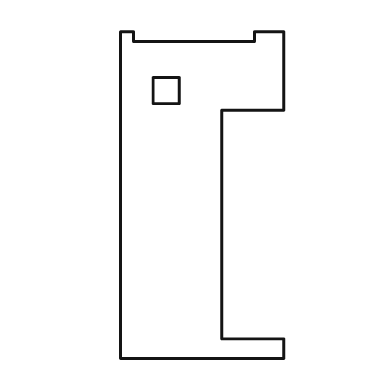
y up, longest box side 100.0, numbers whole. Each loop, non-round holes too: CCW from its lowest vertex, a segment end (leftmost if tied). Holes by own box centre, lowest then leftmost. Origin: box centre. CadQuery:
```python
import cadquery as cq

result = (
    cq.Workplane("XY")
    .moveTo(-25.0, -50.0)
    .lineTo(25.0, -50.0)
    .lineTo(25.0, -44.0)
    .lineTo(6.0, -44.0)
    .lineTo(6.0, 26.0)
    .lineTo(25.0, 26.0)
    .lineTo(25.0, 50.0)
    .lineTo(16.0, 50.0)
    .lineTo(16.0, 47.0)
    .lineTo(-21.0, 47.0)
    .lineTo(-21.0, 50.0)
    .lineTo(-25.0, 50.0)
    .close()
    .moveTo(-15.0, 28.0)
    .lineTo(-7.0, 28.0)
    .lineTo(-7.0, 36.0)
    .lineTo(-15.0, 36.0)
    .close()
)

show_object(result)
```